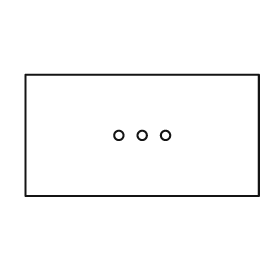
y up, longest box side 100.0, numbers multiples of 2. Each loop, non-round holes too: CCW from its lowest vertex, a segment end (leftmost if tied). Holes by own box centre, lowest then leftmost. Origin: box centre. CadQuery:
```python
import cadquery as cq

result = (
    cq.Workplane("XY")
    .moveTo(-50.0, -26.0)
    .lineTo(50.0, -26.0)
    .lineTo(50.0, 26.0)
    .lineTo(-50.0, 26.0)
    .close()
    .moveTo(-10.0, 0.0)
    .circle(2.0)
    .moveTo(0.0, 0.0)
    .circle(2.0)
    .moveTo(10.0, 0.0)
    .circle(2.0)
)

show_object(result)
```